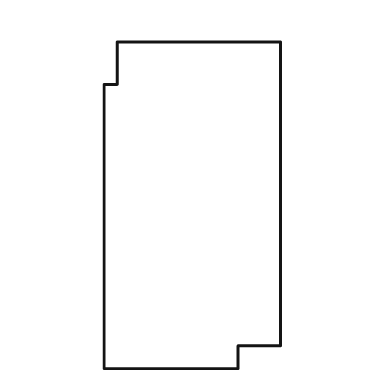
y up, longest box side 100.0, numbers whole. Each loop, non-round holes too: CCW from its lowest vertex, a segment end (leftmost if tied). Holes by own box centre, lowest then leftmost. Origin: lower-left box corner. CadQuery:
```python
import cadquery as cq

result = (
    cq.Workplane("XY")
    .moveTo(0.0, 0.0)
    .lineTo(41.0, 0.0)
    .lineTo(41.0, 7.0)
    .lineTo(54.0, 7.0)
    .lineTo(54.0, 100.0)
    .lineTo(4.0, 100.0)
    .lineTo(4.0, 87.0)
    .lineTo(0.0, 87.0)
    .close()
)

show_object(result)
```